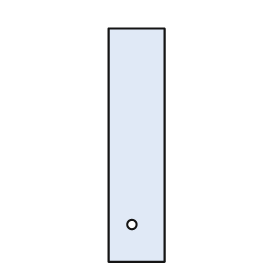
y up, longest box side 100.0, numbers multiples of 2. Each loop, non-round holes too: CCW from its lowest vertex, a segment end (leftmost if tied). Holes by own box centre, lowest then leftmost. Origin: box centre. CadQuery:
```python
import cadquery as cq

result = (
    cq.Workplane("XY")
    .moveTo(-12.0, -50.0)
    .lineTo(12.0, -50.0)
    .lineTo(12.0, 50.0)
    .lineTo(-12.0, 50.0)
    .close()
    .moveTo(-2.0, -34.0)
    .circle(2.0)
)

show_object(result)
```